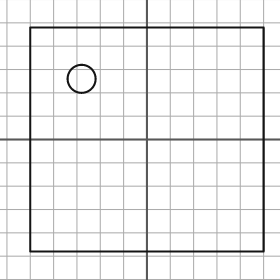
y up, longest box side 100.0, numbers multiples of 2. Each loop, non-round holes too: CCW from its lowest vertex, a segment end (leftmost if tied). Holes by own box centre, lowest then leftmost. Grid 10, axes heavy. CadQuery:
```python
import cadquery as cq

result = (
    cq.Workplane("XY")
    .moveTo(-50.0, -48.0)
    .lineTo(50.0, -48.0)
    .lineTo(50.0, 48.0)
    .lineTo(-50.0, 48.0)
    .close()
    .moveTo(-28.0, 26.0)
    .circle(6.0)
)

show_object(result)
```